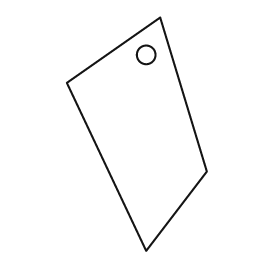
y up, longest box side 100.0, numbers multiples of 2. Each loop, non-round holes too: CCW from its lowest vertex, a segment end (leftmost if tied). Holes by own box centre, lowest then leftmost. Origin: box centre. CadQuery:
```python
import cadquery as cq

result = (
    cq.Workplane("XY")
    .moveTo(4.0, -50.0)
    .lineTo(30.0, -16.0)
    .lineTo(10.0, 50.0)
    .lineTo(-30.0, 22.0)
    .close()
    .moveTo(4.0, 34.0)
    .circle(4.0)
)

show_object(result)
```